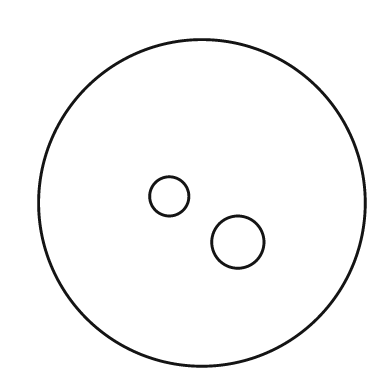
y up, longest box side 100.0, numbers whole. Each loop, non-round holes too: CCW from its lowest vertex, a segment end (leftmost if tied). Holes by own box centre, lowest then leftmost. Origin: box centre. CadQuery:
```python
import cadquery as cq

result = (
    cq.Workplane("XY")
    .moveTo(0.0, 0.0)
    .circle(50.0)
    .moveTo(11.0, -12.0)
    .circle(8.0)
    .moveTo(-10.0, 2.0)
    .circle(6.0)
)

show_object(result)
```